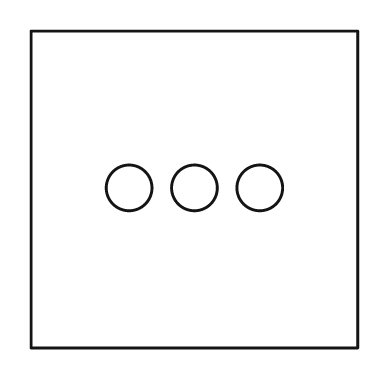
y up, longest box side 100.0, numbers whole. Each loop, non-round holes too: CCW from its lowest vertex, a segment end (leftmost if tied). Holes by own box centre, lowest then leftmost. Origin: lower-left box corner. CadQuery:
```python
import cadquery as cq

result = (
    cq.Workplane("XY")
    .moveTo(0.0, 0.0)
    .lineTo(100.0, 0.0)
    .lineTo(100.0, 97.0)
    .lineTo(0.0, 97.0)
    .close()
    .moveTo(30.0, 49.0)
    .circle(7.0)
    .moveTo(50.0, 49.0)
    .circle(7.0)
    .moveTo(70.0, 49.0)
    .circle(7.0)
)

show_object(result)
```